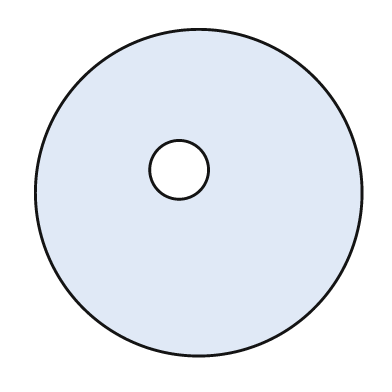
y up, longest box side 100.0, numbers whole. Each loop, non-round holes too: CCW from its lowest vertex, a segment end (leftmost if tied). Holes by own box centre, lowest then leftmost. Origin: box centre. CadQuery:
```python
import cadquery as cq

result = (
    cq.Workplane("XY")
    .moveTo(0.0, 0.0)
    .circle(50.0)
    .moveTo(-6.0, 7.0)
    .circle(9.0)
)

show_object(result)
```